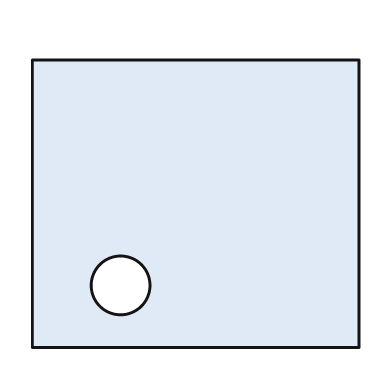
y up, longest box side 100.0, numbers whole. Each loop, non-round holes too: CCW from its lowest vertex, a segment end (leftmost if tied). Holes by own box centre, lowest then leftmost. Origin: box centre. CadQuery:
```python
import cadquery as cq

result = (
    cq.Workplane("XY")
    .moveTo(-50.0, -44.0)
    .lineTo(50.0, -44.0)
    .lineTo(50.0, 44.0)
    .lineTo(-50.0, 44.0)
    .close()
    .moveTo(-23.0, -25.0)
    .circle(9.0)
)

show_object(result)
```